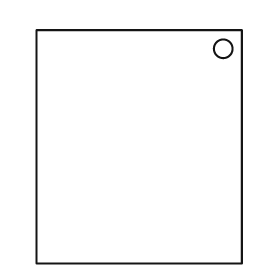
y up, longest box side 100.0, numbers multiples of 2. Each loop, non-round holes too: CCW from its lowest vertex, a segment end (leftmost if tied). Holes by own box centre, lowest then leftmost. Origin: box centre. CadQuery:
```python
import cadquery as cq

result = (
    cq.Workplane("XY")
    .moveTo(-44.0, -50.0)
    .lineTo(44.0, -50.0)
    .lineTo(44.0, 50.0)
    .lineTo(-44.0, 50.0)
    .close()
    .moveTo(36.0, 42.0)
    .circle(4.0)
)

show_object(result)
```